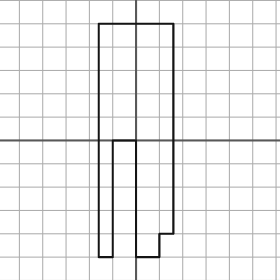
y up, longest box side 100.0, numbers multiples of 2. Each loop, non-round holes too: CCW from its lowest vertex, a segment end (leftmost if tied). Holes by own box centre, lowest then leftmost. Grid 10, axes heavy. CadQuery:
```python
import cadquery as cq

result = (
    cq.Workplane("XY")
    .moveTo(-16.0, -50.0)
    .lineTo(-10.0, -50.0)
    .lineTo(-10.0, 0.0)
    .lineTo(0.0, 0.0)
    .lineTo(0.0, -50.0)
    .lineTo(10.0, -50.0)
    .lineTo(10.0, -40.0)
    .lineTo(16.0, -40.0)
    .lineTo(16.0, 50.0)
    .lineTo(-16.0, 50.0)
    .close()
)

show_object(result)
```